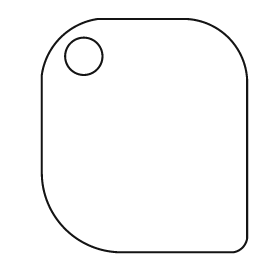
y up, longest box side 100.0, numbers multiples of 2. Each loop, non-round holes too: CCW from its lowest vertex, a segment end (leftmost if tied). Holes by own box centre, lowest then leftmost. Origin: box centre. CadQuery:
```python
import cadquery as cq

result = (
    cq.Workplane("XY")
    .moveTo(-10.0, -50.0)
    .lineTo(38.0, -50.0)
    .threePointArc((42.0, -48.0), (44.0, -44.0))
    .lineTo(44.0, 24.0)
    .threePointArc((36.0, 42.0), (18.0, 50.0))
    .lineTo(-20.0, 50.0)
    .threePointArc((-36.0, 42.0), (-44.0, 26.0))
    .lineTo(-44.0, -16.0)
    .threePointArc((-34.0, -40.0), (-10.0, -50.0))
    .close()
    .moveTo(-26.0, 34.0)
    .circle(8.0)
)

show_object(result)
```